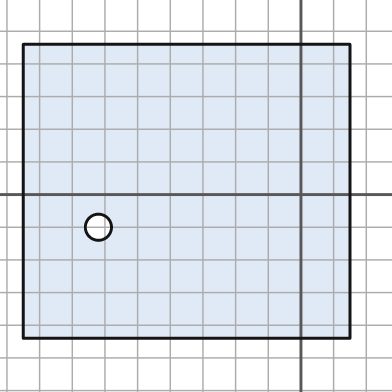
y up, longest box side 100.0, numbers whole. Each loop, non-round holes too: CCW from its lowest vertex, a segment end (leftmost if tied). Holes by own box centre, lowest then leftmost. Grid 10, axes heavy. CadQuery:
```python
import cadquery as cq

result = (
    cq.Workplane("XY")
    .moveTo(-85.0, -44.0)
    .lineTo(15.0, -44.0)
    .lineTo(15.0, 46.0)
    .lineTo(-85.0, 46.0)
    .close()
    .moveTo(-62.0, -10.0)
    .circle(4.0)
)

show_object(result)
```